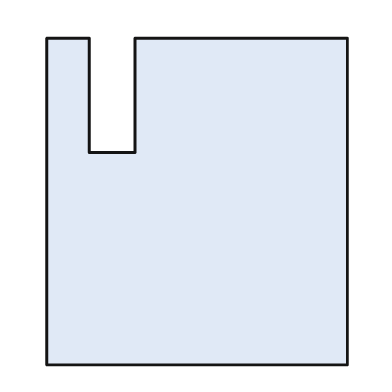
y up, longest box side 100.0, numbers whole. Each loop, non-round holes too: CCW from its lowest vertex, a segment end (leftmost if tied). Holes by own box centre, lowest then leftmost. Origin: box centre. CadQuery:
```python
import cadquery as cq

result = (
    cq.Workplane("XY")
    .moveTo(-46.0, -50.0)
    .lineTo(46.0, -50.0)
    .lineTo(46.0, 50.0)
    .lineTo(-19.0, 50.0)
    .lineTo(-19.0, 15.0)
    .lineTo(-33.0, 15.0)
    .lineTo(-33.0, 50.0)
    .lineTo(-46.0, 50.0)
    .close()
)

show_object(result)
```